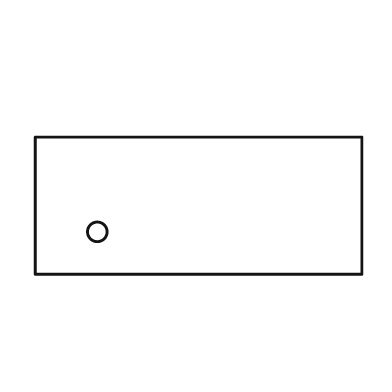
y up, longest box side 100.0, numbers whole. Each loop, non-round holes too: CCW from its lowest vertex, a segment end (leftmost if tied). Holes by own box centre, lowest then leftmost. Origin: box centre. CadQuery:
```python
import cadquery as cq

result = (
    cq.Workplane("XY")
    .moveTo(-50.0, -21.0)
    .lineTo(50.0, -21.0)
    .lineTo(50.0, 21.0)
    .lineTo(-50.0, 21.0)
    .close()
    .moveTo(-31.0, -8.0)
    .circle(3.0)
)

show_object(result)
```